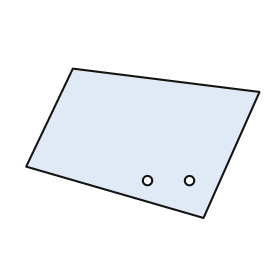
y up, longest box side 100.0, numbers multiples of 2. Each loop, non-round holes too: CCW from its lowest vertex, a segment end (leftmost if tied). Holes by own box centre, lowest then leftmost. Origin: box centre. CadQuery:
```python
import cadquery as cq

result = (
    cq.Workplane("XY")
    .moveTo(26.0, -32.0)
    .lineTo(50.0, 22.0)
    .lineTo(-30.0, 32.0)
    .lineTo(-50.0, -10.0)
    .close()
    .moveTo(2.0, -16.0)
    .circle(2.0)
    .moveTo(20.0, -16.0)
    .circle(2.0)
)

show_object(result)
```